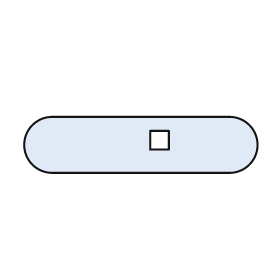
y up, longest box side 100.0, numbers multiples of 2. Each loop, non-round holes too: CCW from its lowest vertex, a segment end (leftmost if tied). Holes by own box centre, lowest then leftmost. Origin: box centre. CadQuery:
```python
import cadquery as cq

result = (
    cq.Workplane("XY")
    .moveTo(-38.0, -12.0)
    .lineTo(38.0, -12.0)
    .threePointArc((50.0, 0.0), (38.0, 12.0))
    .lineTo(-38.0, 12.0)
    .threePointArc((-50.0, 0.0), (-38.0, -12.0))
    .close()
    .moveTo(4.0, -2.0)
    .lineTo(12.0, -2.0)
    .lineTo(12.0, 6.0)
    .lineTo(4.0, 6.0)
    .close()
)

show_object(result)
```